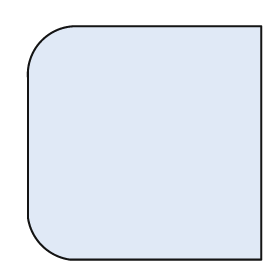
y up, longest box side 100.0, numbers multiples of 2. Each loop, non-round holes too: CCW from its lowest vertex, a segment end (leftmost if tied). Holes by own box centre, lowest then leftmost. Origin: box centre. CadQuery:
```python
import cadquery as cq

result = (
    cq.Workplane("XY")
    .moveTo(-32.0, -50.0)
    .lineTo(50.0, -50.0)
    .lineTo(50.0, 50.0)
    .lineTo(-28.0, 50.0)
    .threePointArc((-44.0, 44.0), (-50.0, 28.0))
    .lineTo(-50.0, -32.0)
    .threePointArc((-44.0, -44.0), (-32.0, -50.0))
    .close()
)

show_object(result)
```